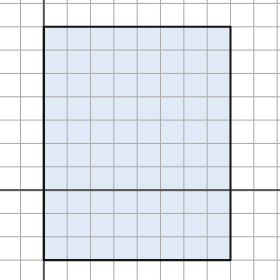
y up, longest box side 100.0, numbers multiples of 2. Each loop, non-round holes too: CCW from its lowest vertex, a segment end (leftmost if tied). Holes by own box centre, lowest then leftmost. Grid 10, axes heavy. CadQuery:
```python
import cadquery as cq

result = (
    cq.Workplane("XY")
    .moveTo(0.0, -30.0)
    .lineTo(80.0, -30.0)
    .lineTo(80.0, 70.0)
    .lineTo(0.0, 70.0)
    .close()
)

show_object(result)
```